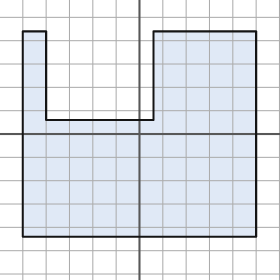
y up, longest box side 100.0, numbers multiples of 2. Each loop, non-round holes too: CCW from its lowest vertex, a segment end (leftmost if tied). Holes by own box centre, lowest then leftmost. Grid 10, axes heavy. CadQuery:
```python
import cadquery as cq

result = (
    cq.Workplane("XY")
    .moveTo(-50.0, -44.0)
    .lineTo(50.0, -44.0)
    .lineTo(50.0, 44.0)
    .lineTo(6.0, 44.0)
    .lineTo(6.0, 6.0)
    .lineTo(-40.0, 6.0)
    .lineTo(-40.0, 44.0)
    .lineTo(-50.0, 44.0)
    .close()
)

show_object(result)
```